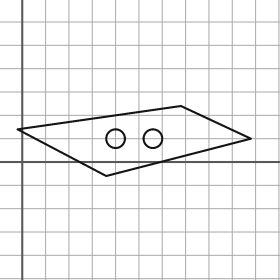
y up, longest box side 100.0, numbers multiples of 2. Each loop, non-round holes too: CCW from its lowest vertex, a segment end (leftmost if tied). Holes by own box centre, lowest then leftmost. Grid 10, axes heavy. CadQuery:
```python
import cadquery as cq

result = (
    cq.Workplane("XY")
    .moveTo(36.0, -6.0)
    .lineTo(98.0, 10.0)
    .lineTo(68.0, 24.0)
    .lineTo(-2.0, 14.0)
    .close()
    .moveTo(40.0, 10.0)
    .circle(4.0)
    .moveTo(56.0, 10.0)
    .circle(4.0)
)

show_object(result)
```